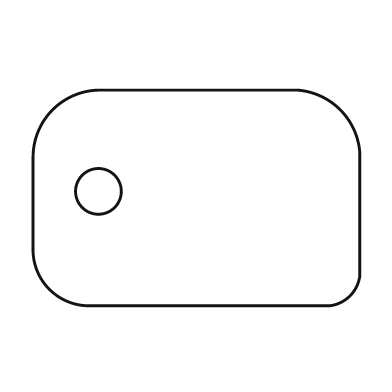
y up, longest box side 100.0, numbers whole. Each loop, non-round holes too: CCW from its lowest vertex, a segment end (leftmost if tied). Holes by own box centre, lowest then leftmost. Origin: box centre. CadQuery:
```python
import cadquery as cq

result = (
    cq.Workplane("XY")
    .moveTo(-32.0, -33.0)
    .lineTo(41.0, -33.0)
    .threePointArc((47.0, -30.0), (50.0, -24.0))
    .lineTo(50.0, 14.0)
    .threePointArc((44.0, 27.0), (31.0, 33.0))
    .lineTo(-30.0, 33.0)
    .threePointArc((-44.0, 27.0), (-50.0, 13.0))
    .lineTo(-50.0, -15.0)
    .threePointArc((-45.0, -28.0), (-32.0, -33.0))
    .close()
    .moveTo(-30.0, 2.0)
    .circle(7.0)
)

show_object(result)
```